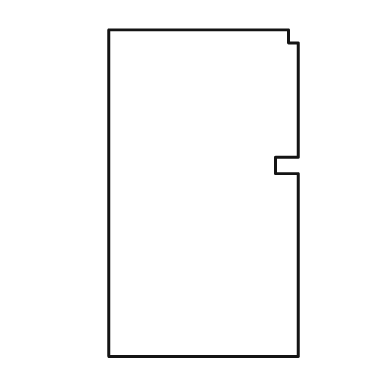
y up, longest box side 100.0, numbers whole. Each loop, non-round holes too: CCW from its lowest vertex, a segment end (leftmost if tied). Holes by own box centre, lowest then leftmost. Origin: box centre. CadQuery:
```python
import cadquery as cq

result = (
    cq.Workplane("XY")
    .moveTo(-29.0, -50.0)
    .lineTo(29.0, -50.0)
    .lineTo(29.0, 6.0)
    .lineTo(22.0, 6.0)
    .lineTo(22.0, 11.0)
    .lineTo(29.0, 11.0)
    .lineTo(29.0, 46.0)
    .lineTo(26.0, 46.0)
    .lineTo(26.0, 50.0)
    .lineTo(-29.0, 50.0)
    .close()
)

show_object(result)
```